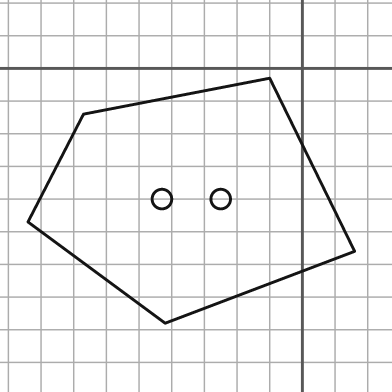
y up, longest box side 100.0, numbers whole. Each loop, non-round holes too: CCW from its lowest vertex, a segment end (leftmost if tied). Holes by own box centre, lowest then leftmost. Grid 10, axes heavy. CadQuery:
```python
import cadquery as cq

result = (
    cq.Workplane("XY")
    .moveTo(-42.0, -78.0)
    .lineTo(16.0, -56.0)
    .lineTo(-10.0, -3.0)
    .lineTo(-67.0, -14.0)
    .lineTo(-84.0, -47.0)
    .close()
    .moveTo(-43.0, -40.0)
    .circle(3.0)
    .moveTo(-25.0, -40.0)
    .circle(3.0)
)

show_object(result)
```